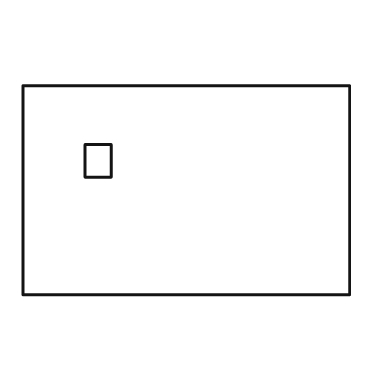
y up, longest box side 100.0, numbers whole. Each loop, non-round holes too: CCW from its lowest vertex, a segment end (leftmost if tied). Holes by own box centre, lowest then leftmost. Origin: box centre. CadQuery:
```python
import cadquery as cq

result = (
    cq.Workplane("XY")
    .moveTo(-50.0, -32.0)
    .lineTo(50.0, -32.0)
    .lineTo(50.0, 32.0)
    .lineTo(-50.0, 32.0)
    .close()
    .moveTo(-31.0, 4.0)
    .lineTo(-23.0, 4.0)
    .lineTo(-23.0, 14.0)
    .lineTo(-31.0, 14.0)
    .close()
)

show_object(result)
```